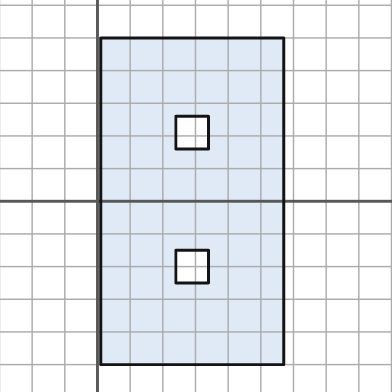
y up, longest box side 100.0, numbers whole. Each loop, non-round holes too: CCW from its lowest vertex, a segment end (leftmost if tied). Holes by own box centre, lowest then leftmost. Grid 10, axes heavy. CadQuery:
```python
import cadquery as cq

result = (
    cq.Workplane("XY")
    .moveTo(1.0, -50.0)
    .lineTo(57.0, -50.0)
    .lineTo(57.0, 50.0)
    .lineTo(1.0, 50.0)
    .close()
    .moveTo(24.0, -25.0)
    .lineTo(34.0, -25.0)
    .lineTo(34.0, -15.0)
    .lineTo(24.0, -15.0)
    .close()
    .moveTo(24.0, 16.0)
    .lineTo(34.0, 16.0)
    .lineTo(34.0, 26.0)
    .lineTo(24.0, 26.0)
    .close()
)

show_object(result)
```